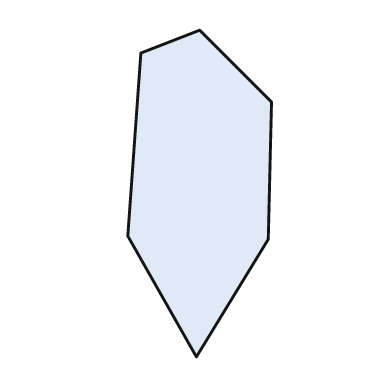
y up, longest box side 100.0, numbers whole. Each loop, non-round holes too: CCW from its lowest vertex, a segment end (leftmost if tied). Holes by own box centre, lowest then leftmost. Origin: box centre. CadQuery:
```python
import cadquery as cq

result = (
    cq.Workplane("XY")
    .moveTo(-1.0, -50.0)
    .lineTo(21.0, -14.0)
    .lineTo(22.0, 28.0)
    .lineTo(0.0, 50.0)
    .lineTo(-18.0, 43.0)
    .lineTo(-22.0, -13.0)
    .close()
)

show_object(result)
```